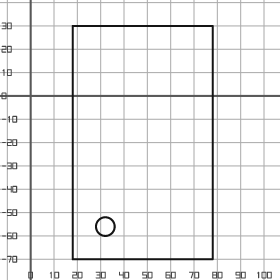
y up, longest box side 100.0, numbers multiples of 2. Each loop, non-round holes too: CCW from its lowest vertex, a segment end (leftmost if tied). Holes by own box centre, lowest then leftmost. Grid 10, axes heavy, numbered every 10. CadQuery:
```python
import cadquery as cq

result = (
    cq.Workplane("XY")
    .moveTo(18.0, -70.0)
    .lineTo(78.0, -70.0)
    .lineTo(78.0, 30.0)
    .lineTo(18.0, 30.0)
    .close()
    .moveTo(32.0, -56.0)
    .circle(4.0)
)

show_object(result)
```